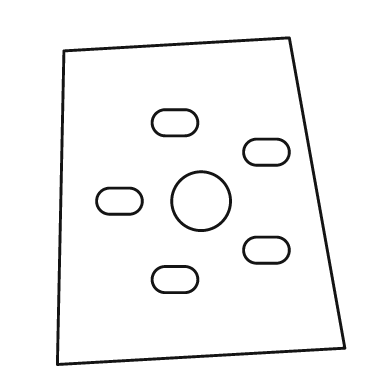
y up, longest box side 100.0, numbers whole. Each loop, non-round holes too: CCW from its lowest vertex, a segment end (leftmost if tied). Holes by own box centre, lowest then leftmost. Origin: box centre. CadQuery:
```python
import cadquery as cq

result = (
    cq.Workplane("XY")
    .moveTo(-44.0, -50.0)
    .lineTo(44.0, -45.0)
    .lineTo(27.0, 50.0)
    .lineTo(-42.0, 46.0)
    .close()
    .moveTo(-11.0, -28.0)
    .lineTo(-5.0, -28.0)
    .threePointArc((-1.0, -24.0), (-5.0, -20.0))
    .lineTo(-11.0, -20.0)
    .threePointArc((-15.0, -24.0), (-11.0, -28.0))
    .close()
    .moveTo(17.0, -19.0)
    .lineTo(23.0, -19.0)
    .threePointArc((27.0, -15.0), (23.0, -11.0))
    .lineTo(17.0, -11.0)
    .threePointArc((13.0, -15.0), (17.0, -19.0))
    .close()
    .moveTo(-28.0, -4.0)
    .lineTo(-22.0, -4.0)
    .threePointArc((-18.0, 0.0), (-22.0, 4.0))
    .lineTo(-28.0, 4.0)
    .threePointArc((-32.0, 0.0), (-28.0, -4.0))
    .close()
    .moveTo(0.0, 0.0)
    .circle(9.0)
    .moveTo(17.0, 11.0)
    .lineTo(23.0, 11.0)
    .threePointArc((27.0, 15.0), (23.0, 19.0))
    .lineTo(17.0, 19.0)
    .threePointArc((13.0, 15.0), (17.0, 11.0))
    .close()
    .moveTo(-11.0, 20.0)
    .lineTo(-5.0, 20.0)
    .threePointArc((-1.0, 24.0), (-5.0, 28.0))
    .lineTo(-11.0, 28.0)
    .threePointArc((-15.0, 24.0), (-11.0, 20.0))
    .close()
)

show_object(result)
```